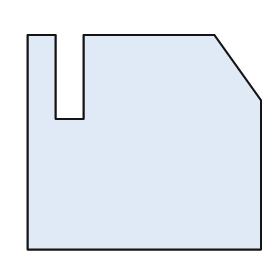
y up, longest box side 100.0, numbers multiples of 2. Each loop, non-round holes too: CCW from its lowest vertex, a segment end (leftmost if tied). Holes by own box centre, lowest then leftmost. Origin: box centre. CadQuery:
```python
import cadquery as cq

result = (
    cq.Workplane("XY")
    .moveTo(-50.0, -46.0)
    .lineTo(50.0, -46.0)
    .lineTo(50.0, 18.0)
    .lineTo(30.0, 46.0)
    .lineTo(-26.0, 46.0)
    .lineTo(-26.0, 10.0)
    .lineTo(-38.0, 10.0)
    .lineTo(-38.0, 46.0)
    .lineTo(-50.0, 46.0)
    .close()
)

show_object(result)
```